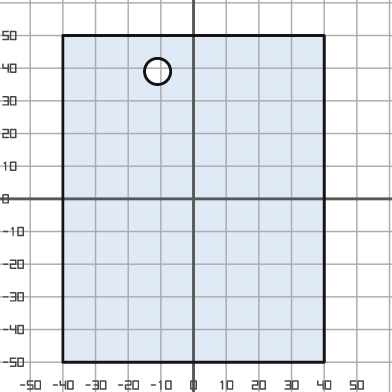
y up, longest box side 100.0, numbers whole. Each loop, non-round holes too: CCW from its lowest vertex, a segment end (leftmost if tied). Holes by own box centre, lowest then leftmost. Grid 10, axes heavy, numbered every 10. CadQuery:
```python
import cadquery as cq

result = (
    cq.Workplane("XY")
    .moveTo(-40.0, -50.0)
    .lineTo(40.0, -50.0)
    .lineTo(40.0, 50.0)
    .lineTo(-40.0, 50.0)
    .close()
    .moveTo(-11.0, 39.0)
    .circle(4.0)
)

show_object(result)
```